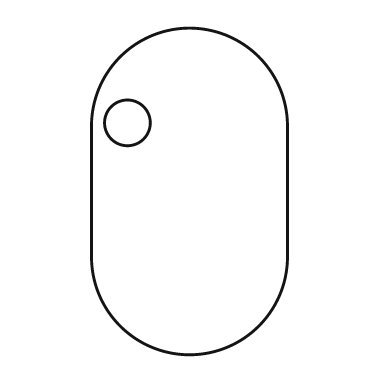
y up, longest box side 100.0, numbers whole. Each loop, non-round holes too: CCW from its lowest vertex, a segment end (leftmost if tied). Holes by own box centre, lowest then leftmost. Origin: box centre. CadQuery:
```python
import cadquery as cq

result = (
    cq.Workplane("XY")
    .moveTo(-30.0, -20.0)
    .threePointArc((0.0, -50.0), (30.0, -20.0))
    .lineTo(30.0, 20.0)
    .threePointArc((0.0, 50.0), (-30.0, 20.0))
    .close()
    .moveTo(-19.0, 21.0)
    .circle(7.0)
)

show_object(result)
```